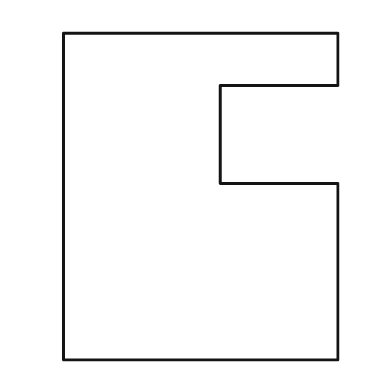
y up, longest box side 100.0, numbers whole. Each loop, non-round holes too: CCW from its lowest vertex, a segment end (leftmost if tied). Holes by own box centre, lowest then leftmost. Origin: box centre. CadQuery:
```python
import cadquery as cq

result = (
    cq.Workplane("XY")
    .moveTo(-42.0, -50.0)
    .lineTo(42.0, -50.0)
    .lineTo(42.0, 4.0)
    .lineTo(6.0, 4.0)
    .lineTo(6.0, 34.0)
    .lineTo(42.0, 34.0)
    .lineTo(42.0, 50.0)
    .lineTo(-42.0, 50.0)
    .close()
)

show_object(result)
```